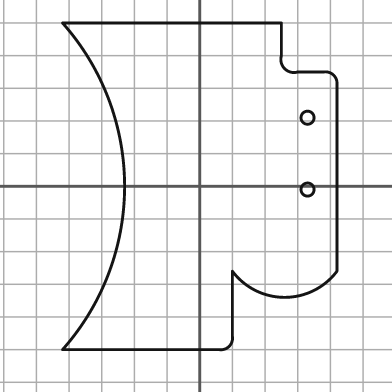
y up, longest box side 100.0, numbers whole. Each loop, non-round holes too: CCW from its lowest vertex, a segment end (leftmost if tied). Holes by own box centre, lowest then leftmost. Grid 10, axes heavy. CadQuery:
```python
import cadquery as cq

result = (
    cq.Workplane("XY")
    .moveTo(-42.0, -50.0)
    .lineTo(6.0, -50.0)
    .threePointArc((9.0, -49.0), (10.0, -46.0))
    .lineTo(10.0, -26.0)
    .threePointArc((26.0, -34.0), (42.0, -26.0))
    .lineTo(42.0, 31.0)
    .threePointArc((41.0, 34.0), (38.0, 35.0))
    .lineTo(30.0, 35.0)
    .threePointArc((26.0, 36.0), (25.0, 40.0))
    .lineTo(25.0, 50.0)
    .lineTo(-42.0, 50.0)
    .threePointArc((-23.0, 0.0), (-42.0, -50.0))
    .close()
    .moveTo(33.0, -1.0)
    .circle(2.0)
    .moveTo(33.0, 21.0)
    .circle(2.0)
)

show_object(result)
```